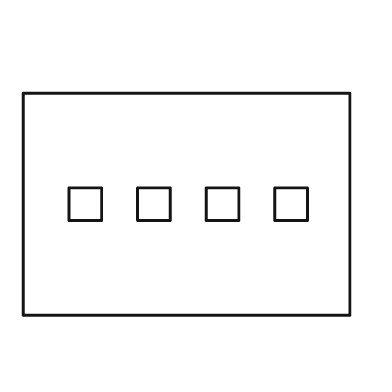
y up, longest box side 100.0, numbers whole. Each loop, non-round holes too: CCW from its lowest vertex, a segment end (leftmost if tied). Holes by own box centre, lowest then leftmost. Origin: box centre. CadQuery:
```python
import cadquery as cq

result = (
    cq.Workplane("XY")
    .moveTo(-50.0, -34.0)
    .lineTo(50.0, -34.0)
    .lineTo(50.0, 34.0)
    .lineTo(-50.0, 34.0)
    .close()
    .moveTo(-36.0, -5.0)
    .lineTo(-26.0, -5.0)
    .lineTo(-26.0, 5.0)
    .lineTo(-36.0, 5.0)
    .close()
    .moveTo(-15.0, -5.0)
    .lineTo(-5.0, -5.0)
    .lineTo(-5.0, 5.0)
    .lineTo(-15.0, 5.0)
    .close()
    .moveTo(6.0, -5.0)
    .lineTo(16.0, -5.0)
    .lineTo(16.0, 5.0)
    .lineTo(6.0, 5.0)
    .close()
    .moveTo(27.0, -5.0)
    .lineTo(37.0, -5.0)
    .lineTo(37.0, 5.0)
    .lineTo(27.0, 5.0)
    .close()
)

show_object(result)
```